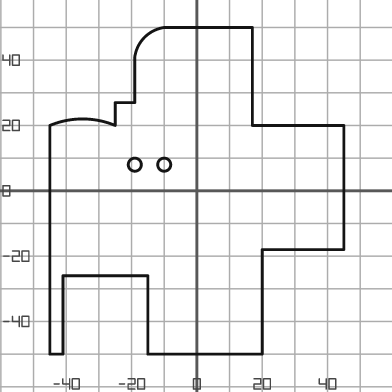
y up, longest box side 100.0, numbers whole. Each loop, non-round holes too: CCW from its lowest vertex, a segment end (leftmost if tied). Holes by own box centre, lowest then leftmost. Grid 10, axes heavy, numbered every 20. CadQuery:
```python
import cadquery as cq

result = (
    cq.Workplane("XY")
    .moveTo(-45.0, -50.0)
    .lineTo(-41.0, -50.0)
    .lineTo(-41.0, -26.0)
    .lineTo(-15.0, -26.0)
    .lineTo(-15.0, -50.0)
    .lineTo(20.0, -50.0)
    .lineTo(20.0, -18.0)
    .lineTo(45.0, -18.0)
    .lineTo(45.0, 20.0)
    .lineTo(17.0, 20.0)
    .lineTo(17.0, 50.0)
    .lineTo(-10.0, 50.0)
    .threePointArc((-16.0, 47.0), (-19.0, 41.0))
    .lineTo(-19.0, 27.0)
    .lineTo(-25.0, 27.0)
    .lineTo(-25.0, 20.0)
    .threePointArc((-35.0, 22.0), (-45.0, 20.0))
    .close()
    .moveTo(-19.0, 8.0)
    .circle(2.0)
    .moveTo(-10.0, 8.0)
    .circle(2.0)
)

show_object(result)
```